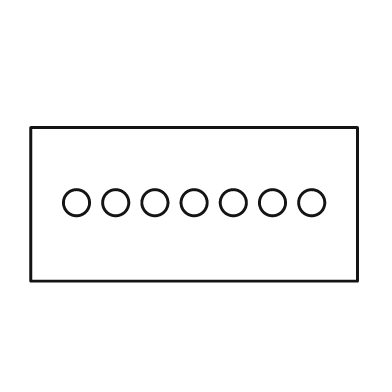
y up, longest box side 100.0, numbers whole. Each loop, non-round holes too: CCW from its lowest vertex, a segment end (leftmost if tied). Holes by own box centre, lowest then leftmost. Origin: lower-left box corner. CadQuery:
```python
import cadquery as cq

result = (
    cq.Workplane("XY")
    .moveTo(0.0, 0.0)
    .lineTo(100.0, 0.0)
    .lineTo(100.0, 47.0)
    .lineTo(0.0, 47.0)
    .close()
    .moveTo(14.0, 24.0)
    .circle(4.0)
    .moveTo(26.0, 24.0)
    .circle(4.0)
    .moveTo(38.0, 24.0)
    .circle(4.0)
    .moveTo(50.0, 24.0)
    .circle(4.0)
    .moveTo(62.0, 24.0)
    .circle(4.0)
    .moveTo(74.0, 24.0)
    .circle(4.0)
    .moveTo(86.0, 24.0)
    .circle(4.0)
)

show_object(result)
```